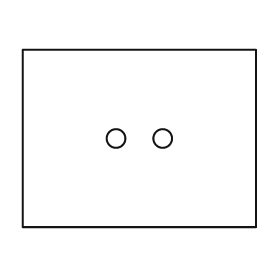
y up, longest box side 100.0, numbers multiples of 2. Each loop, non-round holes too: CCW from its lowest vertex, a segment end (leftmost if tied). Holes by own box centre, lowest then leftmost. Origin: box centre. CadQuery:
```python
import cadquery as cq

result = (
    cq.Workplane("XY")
    .moveTo(-50.0, -38.0)
    .lineTo(50.0, -38.0)
    .lineTo(50.0, 38.0)
    .lineTo(-50.0, 38.0)
    .close()
    .moveTo(-10.0, 0.0)
    .circle(4.0)
    .moveTo(10.0, 0.0)
    .circle(4.0)
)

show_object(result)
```